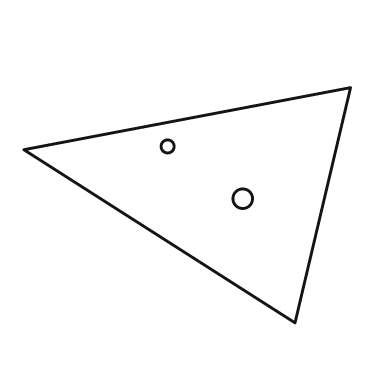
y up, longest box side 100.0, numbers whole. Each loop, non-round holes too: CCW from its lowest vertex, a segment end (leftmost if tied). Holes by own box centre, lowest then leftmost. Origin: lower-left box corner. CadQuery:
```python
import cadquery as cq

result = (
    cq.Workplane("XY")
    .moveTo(83.0, 0.0)
    .lineTo(100.0, 72.0)
    .lineTo(0.0, 53.0)
    .close()
    .moveTo(67.0, 38.0)
    .circle(3.0)
    .moveTo(44.0, 54.0)
    .circle(2.0)
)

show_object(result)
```